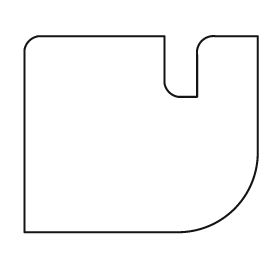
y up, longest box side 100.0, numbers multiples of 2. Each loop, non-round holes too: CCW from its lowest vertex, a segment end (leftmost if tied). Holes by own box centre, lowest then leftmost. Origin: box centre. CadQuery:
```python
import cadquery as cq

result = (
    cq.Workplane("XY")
    .moveTo(-50.0, -42.0)
    .lineTo(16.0, -42.0)
    .threePointArc((40.0, -32.0), (50.0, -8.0))
    .lineTo(50.0, 42.0)
    .lineTo(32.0, 42.0)
    .threePointArc((26.0, 40.0), (24.0, 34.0))
    .lineTo(24.0, 16.0)
    .lineTo(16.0, 16.0)
    .threePointArc((12.0, 18.0), (10.0, 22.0))
    .lineTo(10.0, 42.0)
    .lineTo(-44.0, 42.0)
    .threePointArc((-48.0, 40.0), (-50.0, 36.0))
    .close()
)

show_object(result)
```